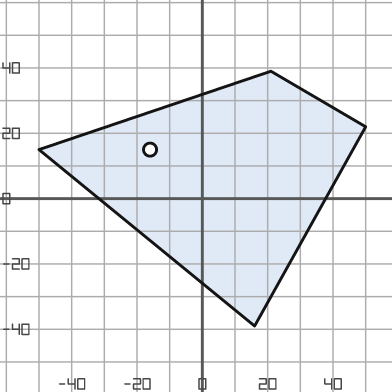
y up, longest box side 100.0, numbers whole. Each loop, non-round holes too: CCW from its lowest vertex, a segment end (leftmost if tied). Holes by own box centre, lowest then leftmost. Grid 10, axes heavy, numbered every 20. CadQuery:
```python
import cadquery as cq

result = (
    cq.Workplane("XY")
    .moveTo(16.0, -39.0)
    .lineTo(50.0, 22.0)
    .lineTo(21.0, 39.0)
    .lineTo(-50.0, 15.0)
    .close()
    .moveTo(-16.0, 15.0)
    .circle(2.0)
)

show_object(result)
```